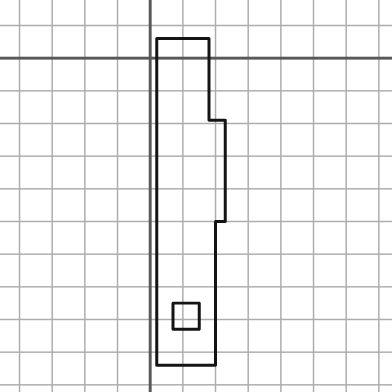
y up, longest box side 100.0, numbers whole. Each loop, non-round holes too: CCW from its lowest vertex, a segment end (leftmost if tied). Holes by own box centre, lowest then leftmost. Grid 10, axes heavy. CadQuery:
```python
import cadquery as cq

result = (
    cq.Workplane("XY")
    .moveTo(2.0, -94.0)
    .lineTo(20.0, -94.0)
    .lineTo(20.0, -50.0)
    .lineTo(23.0, -50.0)
    .lineTo(23.0, -19.0)
    .lineTo(18.0, -19.0)
    .lineTo(18.0, 6.0)
    .lineTo(2.0, 6.0)
    .close()
    .moveTo(7.0, -83.0)
    .lineTo(15.0, -83.0)
    .lineTo(15.0, -75.0)
    .lineTo(7.0, -75.0)
    .close()
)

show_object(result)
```